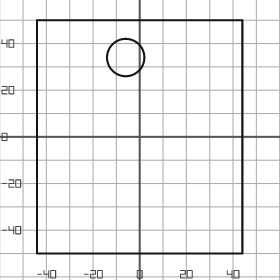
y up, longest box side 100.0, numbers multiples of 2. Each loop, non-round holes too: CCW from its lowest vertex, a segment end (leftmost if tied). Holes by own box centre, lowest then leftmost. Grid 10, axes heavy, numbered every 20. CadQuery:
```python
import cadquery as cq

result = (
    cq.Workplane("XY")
    .moveTo(-44.0, -50.0)
    .lineTo(44.0, -50.0)
    .lineTo(44.0, 50.0)
    .lineTo(-44.0, 50.0)
    .close()
    .moveTo(-6.0, 34.0)
    .circle(8.0)
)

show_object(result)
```